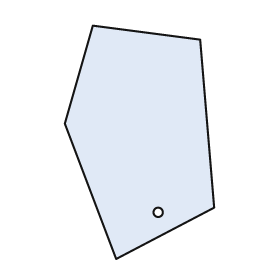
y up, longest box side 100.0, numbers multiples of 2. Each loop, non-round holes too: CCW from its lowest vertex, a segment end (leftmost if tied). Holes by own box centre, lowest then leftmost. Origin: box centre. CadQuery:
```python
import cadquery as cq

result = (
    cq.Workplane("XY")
    .moveTo(-10.0, -50.0)
    .lineTo(32.0, -28.0)
    .lineTo(26.0, 44.0)
    .lineTo(-20.0, 50.0)
    .lineTo(-32.0, 8.0)
    .close()
    .moveTo(8.0, -30.0)
    .circle(2.0)
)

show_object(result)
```